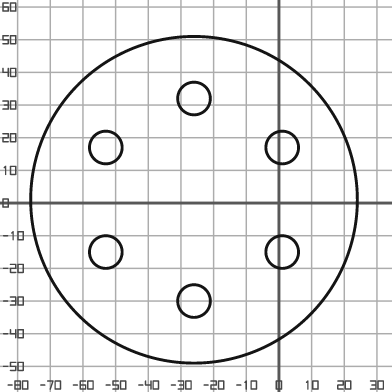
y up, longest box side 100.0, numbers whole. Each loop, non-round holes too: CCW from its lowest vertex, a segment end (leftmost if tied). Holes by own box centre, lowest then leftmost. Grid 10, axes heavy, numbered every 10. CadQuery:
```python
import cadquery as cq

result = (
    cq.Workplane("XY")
    .moveTo(-26.0, 1.0)
    .circle(50.0)
    .moveTo(-26.0, -30.0)
    .circle(5.0)
    .moveTo(-53.0, -15.0)
    .circle(5.0)
    .moveTo(1.0, -15.0)
    .circle(5.0)
    .moveTo(-53.0, 17.0)
    .circle(5.0)
    .moveTo(1.0, 17.0)
    .circle(5.0)
    .moveTo(-26.0, 32.0)
    .circle(5.0)
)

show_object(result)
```